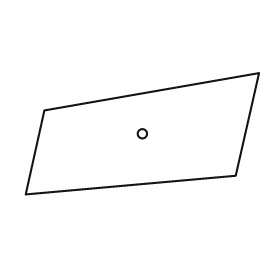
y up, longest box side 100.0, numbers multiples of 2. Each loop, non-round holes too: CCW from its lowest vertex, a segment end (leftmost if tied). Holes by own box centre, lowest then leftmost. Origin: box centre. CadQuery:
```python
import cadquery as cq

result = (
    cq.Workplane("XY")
    .moveTo(-50.0, -26.0)
    .lineTo(40.0, -18.0)
    .lineTo(50.0, 26.0)
    .lineTo(-42.0, 10.0)
    .close()
    .moveTo(0.0, 0.0)
    .circle(2.0)
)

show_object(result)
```